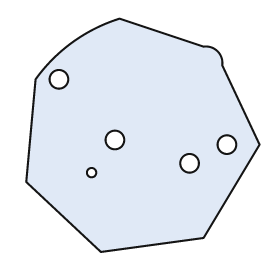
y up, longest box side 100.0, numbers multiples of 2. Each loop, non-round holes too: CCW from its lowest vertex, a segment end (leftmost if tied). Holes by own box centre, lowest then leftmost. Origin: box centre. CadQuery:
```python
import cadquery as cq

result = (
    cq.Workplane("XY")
    .moveTo(-18.0, -50.0)
    .lineTo(26.0, -44.0)
    .lineTo(50.0, -4.0)
    .lineTo(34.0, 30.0)
    .threePointArc((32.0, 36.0), (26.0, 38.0))
    .lineTo(-10.0, 50.0)
    .threePointArc((-30.0, 40.0), (-46.0, 24.0))
    .lineTo(-50.0, -20.0)
    .close()
    .moveTo(-22.0, -16.0)
    .circle(2.0)
    .moveTo(20.0, -12.0)
    .circle(4.0)
    .moveTo(36.0, -4.0)
    .circle(4.0)
    .moveTo(-12.0, -2.0)
    .circle(4.0)
    .moveTo(-36.0, 24.0)
    .circle(4.0)
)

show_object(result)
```